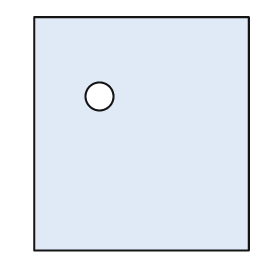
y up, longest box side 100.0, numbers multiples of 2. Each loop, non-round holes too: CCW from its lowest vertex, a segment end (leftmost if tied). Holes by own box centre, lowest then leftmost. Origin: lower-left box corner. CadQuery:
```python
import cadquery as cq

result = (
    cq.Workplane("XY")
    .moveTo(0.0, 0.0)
    .lineTo(92.0, 0.0)
    .lineTo(92.0, 100.0)
    .lineTo(0.0, 100.0)
    .close()
    .moveTo(28.0, 66.0)
    .circle(6.0)
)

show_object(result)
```